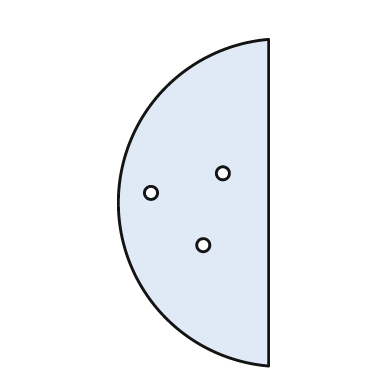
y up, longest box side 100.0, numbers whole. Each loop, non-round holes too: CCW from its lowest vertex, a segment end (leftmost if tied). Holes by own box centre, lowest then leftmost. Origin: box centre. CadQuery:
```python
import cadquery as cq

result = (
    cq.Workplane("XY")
    .moveTo(23.0, -50.0)
    .lineTo(23.0, 50.0)
    .threePointArc((-23.0, 0.0), (23.0, -50.0))
    .close()
    .moveTo(3.0, -13.0)
    .circle(2.0)
    .moveTo(-13.0, 3.0)
    .circle(2.0)
    .moveTo(9.0, 9.0)
    .circle(2.0)
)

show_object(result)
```